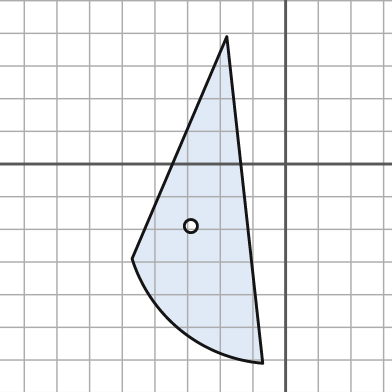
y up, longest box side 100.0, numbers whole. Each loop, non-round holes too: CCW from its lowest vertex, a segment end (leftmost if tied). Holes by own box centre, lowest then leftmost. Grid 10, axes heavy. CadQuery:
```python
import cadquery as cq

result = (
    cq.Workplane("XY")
    .moveTo(-7.0, -61.0)
    .lineTo(-18.0, 39.0)
    .lineTo(-47.0, -29.0)
    .threePointArc((-32.0, -51.0), (-7.0, -61.0))
    .close()
    .moveTo(-29.0, -19.0)
    .circle(2.0)
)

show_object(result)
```